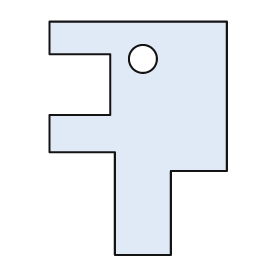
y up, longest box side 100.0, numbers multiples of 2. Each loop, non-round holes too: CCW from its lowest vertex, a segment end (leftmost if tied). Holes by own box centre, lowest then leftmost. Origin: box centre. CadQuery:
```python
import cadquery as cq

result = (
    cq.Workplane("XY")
    .moveTo(-10.0, -50.0)
    .lineTo(14.0, -50.0)
    .lineTo(14.0, -14.0)
    .lineTo(38.0, -14.0)
    .lineTo(38.0, 50.0)
    .lineTo(-38.0, 50.0)
    .lineTo(-38.0, 36.0)
    .lineTo(-12.0, 36.0)
    .lineTo(-12.0, 10.0)
    .lineTo(-38.0, 10.0)
    .lineTo(-38.0, -6.0)
    .lineTo(-10.0, -6.0)
    .close()
    .moveTo(2.0, 34.0)
    .circle(6.0)
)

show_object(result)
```